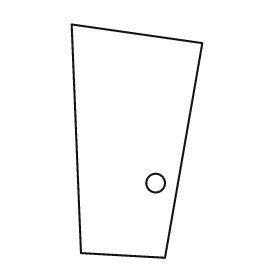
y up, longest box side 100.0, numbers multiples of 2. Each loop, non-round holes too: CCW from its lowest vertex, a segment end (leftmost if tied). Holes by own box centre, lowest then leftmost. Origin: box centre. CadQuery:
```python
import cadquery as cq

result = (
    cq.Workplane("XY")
    .moveTo(12.0, -50.0)
    .lineTo(28.0, 42.0)
    .lineTo(-28.0, 50.0)
    .lineTo(-24.0, -48.0)
    .close()
    .moveTo(8.0, -18.0)
    .circle(4.0)
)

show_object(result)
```